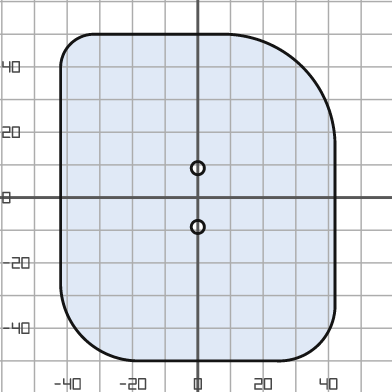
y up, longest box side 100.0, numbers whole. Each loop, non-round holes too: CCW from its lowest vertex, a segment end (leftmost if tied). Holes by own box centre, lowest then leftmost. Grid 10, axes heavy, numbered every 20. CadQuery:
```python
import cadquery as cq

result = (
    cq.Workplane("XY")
    .moveTo(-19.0, -50.0)
    .lineTo(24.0, -50.0)
    .threePointArc((37.0, -45.0), (42.0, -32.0))
    .lineTo(42.0, 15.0)
    .threePointArc((32.0, 40.0), (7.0, 50.0))
    .lineTo(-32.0, 50.0)
    .threePointArc((-39.0, 47.0), (-42.0, 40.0))
    .lineTo(-42.0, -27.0)
    .threePointArc((-35.0, -43.0), (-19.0, -50.0))
    .close()
    .moveTo(0.0, -9.0)
    .circle(2.0)
    .moveTo(0.0, 9.0)
    .circle(2.0)
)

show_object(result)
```